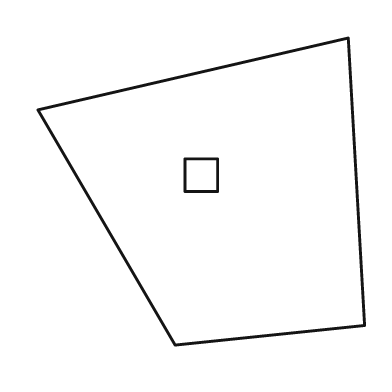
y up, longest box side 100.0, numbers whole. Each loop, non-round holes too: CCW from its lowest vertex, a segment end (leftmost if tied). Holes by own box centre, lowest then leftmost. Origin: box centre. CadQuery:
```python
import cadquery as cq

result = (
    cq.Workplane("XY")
    .moveTo(-8.0, -47.0)
    .lineTo(50.0, -41.0)
    .lineTo(45.0, 47.0)
    .lineTo(-50.0, 25.0)
    .close()
    .moveTo(-5.0, 0.0)
    .lineTo(5.0, 0.0)
    .lineTo(5.0, 10.0)
    .lineTo(-5.0, 10.0)
    .close()
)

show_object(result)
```